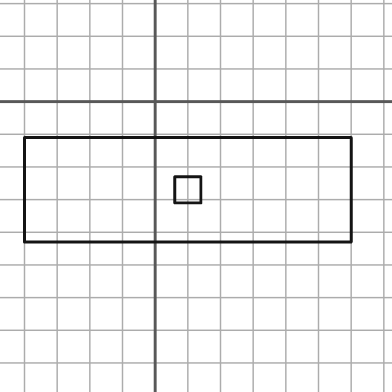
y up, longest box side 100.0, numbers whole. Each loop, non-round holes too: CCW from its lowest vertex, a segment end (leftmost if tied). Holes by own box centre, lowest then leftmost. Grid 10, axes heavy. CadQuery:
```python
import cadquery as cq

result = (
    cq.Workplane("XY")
    .moveTo(-40.0, -43.0)
    .lineTo(60.0, -43.0)
    .lineTo(60.0, -11.0)
    .lineTo(-40.0, -11.0)
    .close()
    .moveTo(6.0, -31.0)
    .lineTo(14.0, -31.0)
    .lineTo(14.0, -23.0)
    .lineTo(6.0, -23.0)
    .close()
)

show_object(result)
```